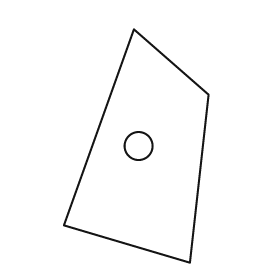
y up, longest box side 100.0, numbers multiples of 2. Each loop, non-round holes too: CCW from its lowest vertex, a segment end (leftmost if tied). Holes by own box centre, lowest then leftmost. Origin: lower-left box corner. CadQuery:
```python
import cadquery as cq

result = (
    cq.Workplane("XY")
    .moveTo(54.0, 0.0)
    .lineTo(62.0, 72.0)
    .lineTo(30.0, 100.0)
    .lineTo(0.0, 16.0)
    .close()
    .moveTo(32.0, 50.0)
    .circle(6.0)
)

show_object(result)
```